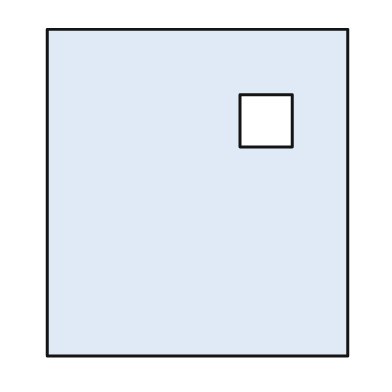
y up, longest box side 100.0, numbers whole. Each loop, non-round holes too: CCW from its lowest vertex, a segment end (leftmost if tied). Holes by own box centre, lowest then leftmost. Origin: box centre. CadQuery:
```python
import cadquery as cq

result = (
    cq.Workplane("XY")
    .moveTo(-46.0, -50.0)
    .lineTo(46.0, -50.0)
    .lineTo(46.0, 50.0)
    .lineTo(-46.0, 50.0)
    .close()
    .moveTo(13.0, 14.0)
    .lineTo(29.0, 14.0)
    .lineTo(29.0, 30.0)
    .lineTo(13.0, 30.0)
    .close()
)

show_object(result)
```